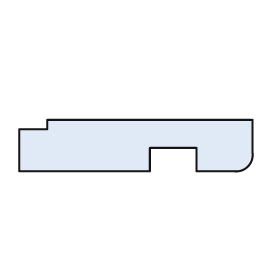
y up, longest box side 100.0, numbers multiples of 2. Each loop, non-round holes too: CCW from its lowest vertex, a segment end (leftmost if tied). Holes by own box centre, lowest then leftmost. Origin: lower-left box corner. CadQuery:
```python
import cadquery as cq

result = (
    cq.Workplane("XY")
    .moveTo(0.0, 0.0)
    .lineTo(56.0, 0.0)
    .lineTo(56.0, 10.0)
    .lineTo(76.0, 10.0)
    .lineTo(76.0, 0.0)
    .lineTo(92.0, 0.0)
    .threePointArc((98.0, 2.0), (100.0, 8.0))
    .lineTo(100.0, 22.0)
    .lineTo(12.0, 22.0)
    .lineTo(12.0, 18.0)
    .lineTo(0.0, 18.0)
    .close()
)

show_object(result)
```